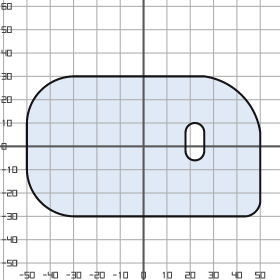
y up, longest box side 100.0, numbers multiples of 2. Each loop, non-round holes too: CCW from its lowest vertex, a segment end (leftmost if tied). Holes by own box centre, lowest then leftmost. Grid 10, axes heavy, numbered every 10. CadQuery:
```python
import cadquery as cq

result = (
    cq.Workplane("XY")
    .moveTo(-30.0, -30.0)
    .lineTo(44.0, -30.0)
    .threePointArc((48.0, -28.0), (50.0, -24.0))
    .lineTo(50.0, 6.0)
    .threePointArc((42.0, 22.0), (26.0, 30.0))
    .lineTo(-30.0, 30.0)
    .threePointArc((-44.0, 24.0), (-50.0, 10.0))
    .lineTo(-50.0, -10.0)
    .threePointArc((-44.0, -24.0), (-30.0, -30.0))
    .close()
    .moveTo(18.0, -2.0)
    .threePointArc((22.0, -6.0), (26.0, -2.0))
    .lineTo(26.0, 6.0)
    .threePointArc((22.0, 10.0), (18.0, 6.0))
    .close()
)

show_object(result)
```